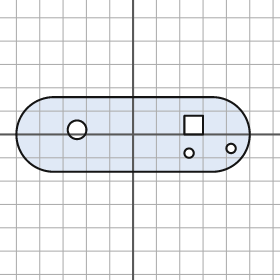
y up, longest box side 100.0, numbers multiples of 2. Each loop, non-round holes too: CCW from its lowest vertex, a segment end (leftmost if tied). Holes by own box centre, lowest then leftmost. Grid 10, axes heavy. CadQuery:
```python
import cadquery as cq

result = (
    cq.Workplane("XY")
    .moveTo(-34.0, -16.0)
    .lineTo(34.0, -16.0)
    .threePointArc((50.0, 0.0), (34.0, 16.0))
    .lineTo(-34.0, 16.0)
    .threePointArc((-50.0, 0.0), (-34.0, -16.0))
    .close()
    .moveTo(24.0, -8.0)
    .circle(2.0)
    .moveTo(42.0, -6.0)
    .circle(2.0)
    .moveTo(-24.0, 2.0)
    .circle(4.0)
    .moveTo(22.0, 0.0)
    .lineTo(30.0, 0.0)
    .lineTo(30.0, 8.0)
    .lineTo(22.0, 8.0)
    .close()
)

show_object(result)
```